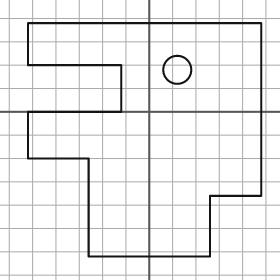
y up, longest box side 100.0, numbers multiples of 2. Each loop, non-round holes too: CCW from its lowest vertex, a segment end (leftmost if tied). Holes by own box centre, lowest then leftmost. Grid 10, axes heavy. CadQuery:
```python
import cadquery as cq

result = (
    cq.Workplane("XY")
    .moveTo(-26.0, -62.0)
    .lineTo(26.0, -62.0)
    .lineTo(26.0, -36.0)
    .lineTo(48.0, -36.0)
    .lineTo(48.0, 38.0)
    .lineTo(-52.0, 38.0)
    .lineTo(-52.0, 20.0)
    .lineTo(-12.0, 20.0)
    .lineTo(-12.0, 0.0)
    .lineTo(-52.0, 0.0)
    .lineTo(-52.0, -20.0)
    .lineTo(-26.0, -20.0)
    .close()
    .moveTo(12.0, 18.0)
    .circle(6.0)
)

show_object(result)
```